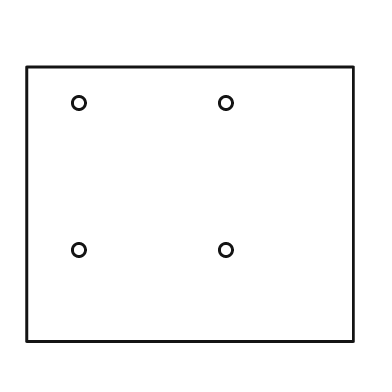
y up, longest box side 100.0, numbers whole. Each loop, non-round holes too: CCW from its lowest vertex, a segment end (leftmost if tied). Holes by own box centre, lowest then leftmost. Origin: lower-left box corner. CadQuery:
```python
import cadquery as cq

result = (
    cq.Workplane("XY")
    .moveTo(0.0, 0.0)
    .lineTo(100.0, 0.0)
    .lineTo(100.0, 84.0)
    .lineTo(0.0, 84.0)
    .close()
    .moveTo(16.0, 28.0)
    .circle(2.0)
    .moveTo(61.0, 28.0)
    .circle(2.0)
    .moveTo(16.0, 73.0)
    .circle(2.0)
    .moveTo(61.0, 73.0)
    .circle(2.0)
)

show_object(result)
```